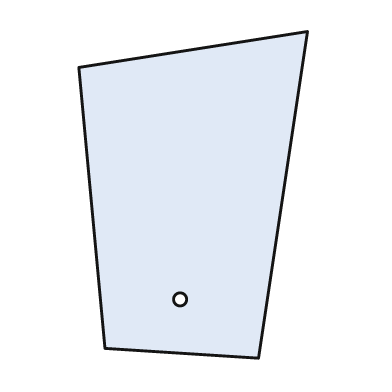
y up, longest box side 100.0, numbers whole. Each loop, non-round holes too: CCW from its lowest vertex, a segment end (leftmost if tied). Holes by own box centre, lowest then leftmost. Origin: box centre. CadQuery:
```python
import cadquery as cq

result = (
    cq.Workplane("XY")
    .moveTo(20.0, -50.0)
    .lineTo(35.0, 50.0)
    .lineTo(-35.0, 39.0)
    .lineTo(-27.0, -47.0)
    .close()
    .moveTo(-4.0, -32.0)
    .circle(2.0)
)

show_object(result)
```